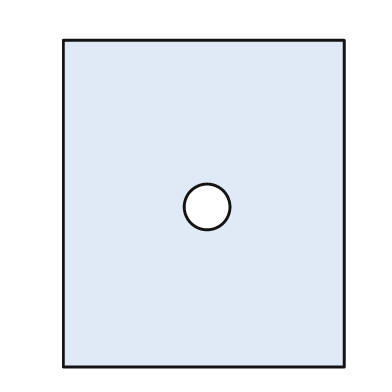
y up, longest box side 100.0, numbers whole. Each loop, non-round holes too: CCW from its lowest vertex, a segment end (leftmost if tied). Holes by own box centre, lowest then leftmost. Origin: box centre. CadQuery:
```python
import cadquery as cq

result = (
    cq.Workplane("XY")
    .moveTo(-43.0, -50.0)
    .lineTo(43.0, -50.0)
    .lineTo(43.0, 50.0)
    .lineTo(-43.0, 50.0)
    .close()
    .moveTo(1.0, -1.0)
    .circle(7.0)
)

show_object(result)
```